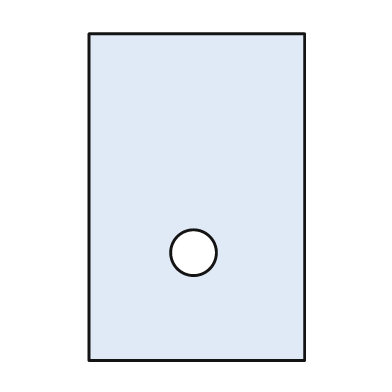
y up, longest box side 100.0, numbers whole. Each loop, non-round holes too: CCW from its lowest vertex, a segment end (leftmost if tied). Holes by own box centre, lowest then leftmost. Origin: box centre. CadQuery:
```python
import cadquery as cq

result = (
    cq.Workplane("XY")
    .moveTo(-33.0, -50.0)
    .lineTo(33.0, -50.0)
    .lineTo(33.0, 50.0)
    .lineTo(-33.0, 50.0)
    .close()
    .moveTo(-1.0, -17.0)
    .circle(7.0)
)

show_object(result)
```